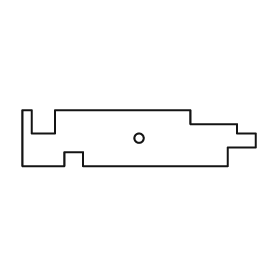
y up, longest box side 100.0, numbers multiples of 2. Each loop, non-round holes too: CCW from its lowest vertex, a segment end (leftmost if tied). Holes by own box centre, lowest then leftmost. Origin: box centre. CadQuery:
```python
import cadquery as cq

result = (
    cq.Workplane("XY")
    .moveTo(-50.0, -12.0)
    .lineTo(-32.0, -12.0)
    .lineTo(-32.0, -6.0)
    .lineTo(-24.0, -6.0)
    .lineTo(-24.0, -12.0)
    .lineTo(38.0, -12.0)
    .lineTo(38.0, -4.0)
    .lineTo(50.0, -4.0)
    .lineTo(50.0, 2.0)
    .lineTo(42.0, 2.0)
    .lineTo(42.0, 6.0)
    .lineTo(22.0, 6.0)
    .lineTo(22.0, 12.0)
    .lineTo(-36.0, 12.0)
    .lineTo(-36.0, 2.0)
    .lineTo(-46.0, 2.0)
    .lineTo(-46.0, 12.0)
    .lineTo(-50.0, 12.0)
    .close()
    .moveTo(0.0, 0.0)
    .circle(2.0)
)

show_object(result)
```